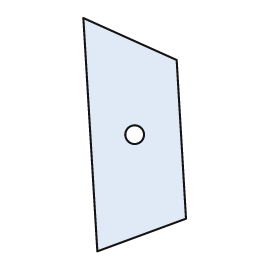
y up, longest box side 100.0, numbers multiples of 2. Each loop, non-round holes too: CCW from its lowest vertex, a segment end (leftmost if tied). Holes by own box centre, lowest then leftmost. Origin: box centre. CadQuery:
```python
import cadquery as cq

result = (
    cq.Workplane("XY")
    .moveTo(-16.0, -50.0)
    .lineTo(22.0, -36.0)
    .lineTo(18.0, 32.0)
    .lineTo(-22.0, 50.0)
    .close()
    .moveTo(0.0, 0.0)
    .circle(4.0)
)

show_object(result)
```